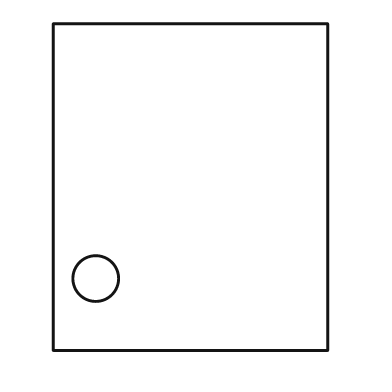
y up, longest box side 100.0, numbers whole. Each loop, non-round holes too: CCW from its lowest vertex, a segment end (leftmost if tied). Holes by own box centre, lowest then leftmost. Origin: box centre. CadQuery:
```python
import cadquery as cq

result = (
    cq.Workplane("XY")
    .moveTo(-42.0, -50.0)
    .lineTo(42.0, -50.0)
    .lineTo(42.0, 50.0)
    .lineTo(-42.0, 50.0)
    .close()
    .moveTo(-29.0, -28.0)
    .circle(7.0)
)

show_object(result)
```